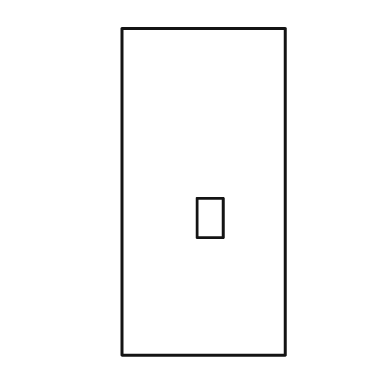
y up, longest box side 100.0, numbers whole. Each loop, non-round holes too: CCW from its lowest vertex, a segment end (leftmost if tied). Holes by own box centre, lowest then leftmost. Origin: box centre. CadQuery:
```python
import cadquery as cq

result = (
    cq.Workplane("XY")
    .moveTo(-25.0, -50.0)
    .lineTo(25.0, -50.0)
    .lineTo(25.0, 50.0)
    .lineTo(-25.0, 50.0)
    .close()
    .moveTo(-2.0, -14.0)
    .lineTo(6.0, -14.0)
    .lineTo(6.0, -2.0)
    .lineTo(-2.0, -2.0)
    .close()
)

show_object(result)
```